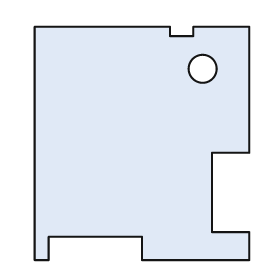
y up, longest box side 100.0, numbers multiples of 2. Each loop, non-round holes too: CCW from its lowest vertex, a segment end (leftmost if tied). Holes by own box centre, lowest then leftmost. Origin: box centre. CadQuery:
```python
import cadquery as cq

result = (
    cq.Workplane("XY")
    .moveTo(-46.0, -50.0)
    .lineTo(-40.0, -50.0)
    .lineTo(-40.0, -40.0)
    .lineTo(0.0, -40.0)
    .lineTo(0.0, -50.0)
    .lineTo(46.0, -50.0)
    .lineTo(46.0, -38.0)
    .lineTo(30.0, -38.0)
    .lineTo(30.0, -4.0)
    .lineTo(46.0, -4.0)
    .lineTo(46.0, 50.0)
    .lineTo(22.0, 50.0)
    .lineTo(22.0, 46.0)
    .lineTo(12.0, 46.0)
    .lineTo(12.0, 50.0)
    .lineTo(-46.0, 50.0)
    .close()
    .moveTo(26.0, 32.0)
    .circle(6.0)
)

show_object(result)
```